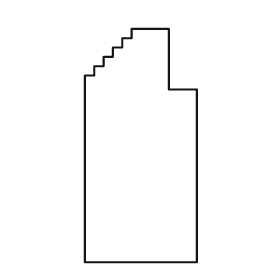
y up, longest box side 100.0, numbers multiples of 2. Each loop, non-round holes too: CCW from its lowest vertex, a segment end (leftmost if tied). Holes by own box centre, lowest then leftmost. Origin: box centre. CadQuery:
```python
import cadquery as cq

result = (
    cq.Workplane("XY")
    .moveTo(-24.0, -50.0)
    .lineTo(24.0, -50.0)
    .lineTo(24.0, 24.0)
    .lineTo(12.0, 24.0)
    .lineTo(12.0, 50.0)
    .lineTo(-4.0, 50.0)
    .lineTo(-4.0, 46.0)
    .lineTo(-8.0, 46.0)
    .lineTo(-8.0, 42.0)
    .lineTo(-12.0, 42.0)
    .lineTo(-12.0, 38.0)
    .lineTo(-16.0, 38.0)
    .lineTo(-16.0, 34.0)
    .lineTo(-20.0, 34.0)
    .lineTo(-20.0, 30.0)
    .lineTo(-24.0, 30.0)
    .close()
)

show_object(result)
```